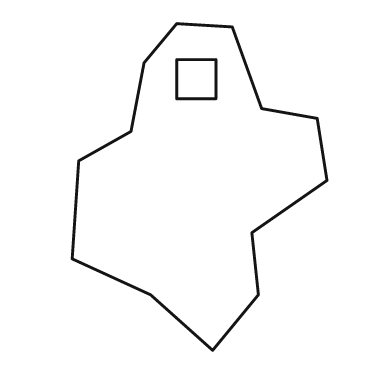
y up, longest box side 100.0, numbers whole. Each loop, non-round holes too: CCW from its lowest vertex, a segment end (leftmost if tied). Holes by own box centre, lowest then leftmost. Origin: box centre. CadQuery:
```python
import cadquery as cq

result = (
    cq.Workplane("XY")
    .moveTo(4.0, -50.0)
    .lineTo(18.0, -33.0)
    .lineTo(16.0, -14.0)
    .lineTo(39.0, 2.0)
    .lineTo(36.0, 21.0)
    .lineTo(19.0, 24.0)
    .lineTo(10.0, 49.0)
    .lineTo(-7.0, 50.0)
    .lineTo(-17.0, 38.0)
    .lineTo(-21.0, 17.0)
    .lineTo(-37.0, 8.0)
    .lineTo(-39.0, -22.0)
    .lineTo(-15.0, -33.0)
    .close()
    .moveTo(-7.0, 27.0)
    .lineTo(5.0, 27.0)
    .lineTo(5.0, 39.0)
    .lineTo(-7.0, 39.0)
    .close()
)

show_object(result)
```